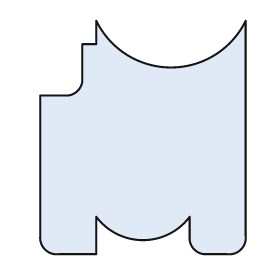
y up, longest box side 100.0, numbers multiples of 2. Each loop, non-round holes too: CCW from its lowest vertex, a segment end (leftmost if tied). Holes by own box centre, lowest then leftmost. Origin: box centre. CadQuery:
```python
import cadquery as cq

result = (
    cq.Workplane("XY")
    .moveTo(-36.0, -50.0)
    .lineTo(-20.0, -50.0)
    .lineTo(-20.0, -34.0)
    .threePointArc((0.0, -44.0), (20.0, -34.0))
    .lineTo(20.0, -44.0)
    .threePointArc((22.0, -48.0), (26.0, -50.0))
    .lineTo(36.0, -50.0)
    .threePointArc((42.0, -48.0), (44.0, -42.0))
    .lineTo(44.0, 50.0)
    .threePointArc((12.0, 30.0), (-20.0, 50.0))
    .lineTo(-20.0, 40.0)
    .lineTo(-26.0, 40.0)
    .lineTo(-26.0, 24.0)
    .threePointArc((-28.0, 20.0), (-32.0, 18.0))
    .lineTo(-44.0, 18.0)
    .lineTo(-44.0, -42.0)
    .threePointArc((-42.0, -48.0), (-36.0, -50.0))
    .close()
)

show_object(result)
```